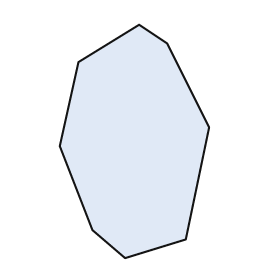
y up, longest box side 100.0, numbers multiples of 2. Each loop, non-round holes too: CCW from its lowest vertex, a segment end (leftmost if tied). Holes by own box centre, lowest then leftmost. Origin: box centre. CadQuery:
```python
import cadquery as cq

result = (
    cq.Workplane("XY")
    .moveTo(-4.0, -50.0)
    .lineTo(22.0, -42.0)
    .lineTo(32.0, 6.0)
    .lineTo(14.0, 42.0)
    .lineTo(2.0, 50.0)
    .lineTo(-24.0, 34.0)
    .lineTo(-32.0, -2.0)
    .lineTo(-18.0, -38.0)
    .close()
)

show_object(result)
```